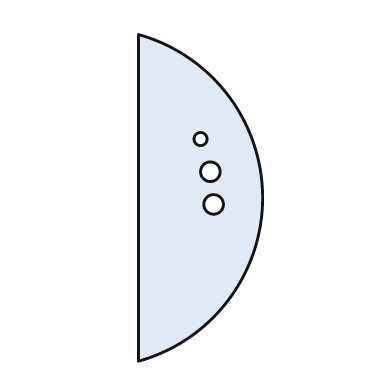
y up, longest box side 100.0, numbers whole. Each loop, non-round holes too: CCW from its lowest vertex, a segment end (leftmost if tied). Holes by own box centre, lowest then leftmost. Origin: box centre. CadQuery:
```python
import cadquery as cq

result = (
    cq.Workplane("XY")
    .moveTo(-19.0, -50.0)
    .threePointArc((19.0, 0.0), (-19.0, 50.0))
    .close()
    .moveTo(4.0, -2.0)
    .circle(3.0)
    .moveTo(3.0, 8.0)
    .circle(3.0)
    .moveTo(0.0, 18.0)
    .circle(2.0)
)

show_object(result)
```